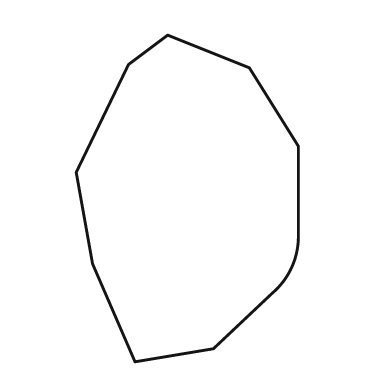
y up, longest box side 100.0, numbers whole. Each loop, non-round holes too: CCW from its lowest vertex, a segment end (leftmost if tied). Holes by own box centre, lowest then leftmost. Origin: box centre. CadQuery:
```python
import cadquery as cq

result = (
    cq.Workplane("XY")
    .moveTo(-16.0, -50.0)
    .lineTo(8.0, -46.0)
    .lineTo(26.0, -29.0)
    .threePointArc((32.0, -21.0), (34.0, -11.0))
    .lineTo(34.0, 16.0)
    .lineTo(19.0, 40.0)
    .lineTo(-6.0, 50.0)
    .lineTo(-18.0, 41.0)
    .lineTo(-34.0, 8.0)
    .lineTo(-29.0, -20.0)
    .close()
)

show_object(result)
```